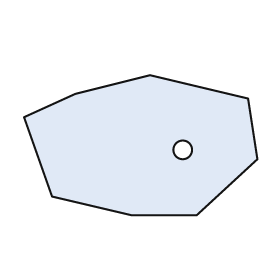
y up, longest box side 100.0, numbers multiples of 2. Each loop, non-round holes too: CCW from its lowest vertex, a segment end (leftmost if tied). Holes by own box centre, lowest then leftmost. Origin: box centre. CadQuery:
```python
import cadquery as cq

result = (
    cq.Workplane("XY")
    .moveTo(-4.0, -30.0)
    .lineTo(24.0, -30.0)
    .lineTo(50.0, -6.0)
    .lineTo(46.0, 20.0)
    .lineTo(4.0, 30.0)
    .lineTo(-28.0, 22.0)
    .lineTo(-50.0, 12.0)
    .lineTo(-38.0, -22.0)
    .close()
    .moveTo(18.0, -2.0)
    .circle(4.0)
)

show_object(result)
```